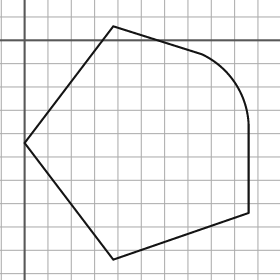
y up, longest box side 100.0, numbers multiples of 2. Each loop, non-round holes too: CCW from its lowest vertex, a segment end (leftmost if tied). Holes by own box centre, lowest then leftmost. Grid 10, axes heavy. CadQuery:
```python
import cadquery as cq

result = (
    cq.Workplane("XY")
    .moveTo(38.0, -94.0)
    .lineTo(96.0, -74.0)
    .lineTo(96.0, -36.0)
    .threePointArc((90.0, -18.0), (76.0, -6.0))
    .lineTo(38.0, 6.0)
    .lineTo(0.0, -44.0)
    .close()
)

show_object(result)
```